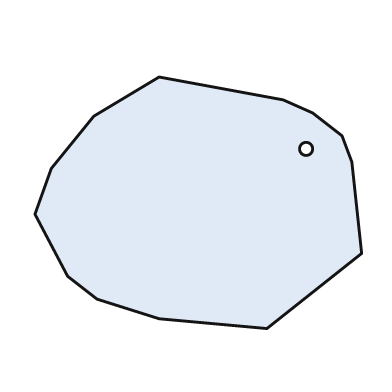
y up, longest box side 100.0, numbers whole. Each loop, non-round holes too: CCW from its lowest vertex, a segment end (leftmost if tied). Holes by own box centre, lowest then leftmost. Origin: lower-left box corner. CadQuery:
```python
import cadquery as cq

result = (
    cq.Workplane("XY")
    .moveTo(71.0, 0.0)
    .lineTo(100.0, 23.0)
    .lineTo(97.0, 51.0)
    .lineTo(94.0, 59.0)
    .lineTo(85.0, 66.0)
    .lineTo(76.0, 70.0)
    .lineTo(38.0, 77.0)
    .lineTo(18.0, 65.0)
    .lineTo(5.0, 49.0)
    .lineTo(0.0, 35.0)
    .lineTo(10.0, 16.0)
    .lineTo(19.0, 9.0)
    .lineTo(38.0, 3.0)
    .close()
    .moveTo(83.0, 55.0)
    .circle(2.0)
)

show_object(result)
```